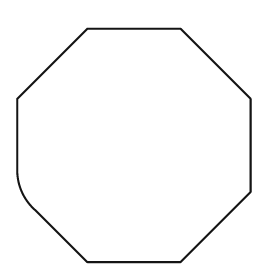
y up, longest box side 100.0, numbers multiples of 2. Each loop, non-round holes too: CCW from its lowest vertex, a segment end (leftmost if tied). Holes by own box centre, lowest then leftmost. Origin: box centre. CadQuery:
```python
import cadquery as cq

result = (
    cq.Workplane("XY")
    .moveTo(-20.0, -50.0)
    .lineTo(20.0, -50.0)
    .lineTo(50.0, -20.0)
    .lineTo(50.0, 20.0)
    .lineTo(20.0, 50.0)
    .lineTo(-20.0, 50.0)
    .lineTo(-50.0, 20.0)
    .lineTo(-50.0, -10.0)
    .threePointArc((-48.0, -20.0), (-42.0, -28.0))
    .close()
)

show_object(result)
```